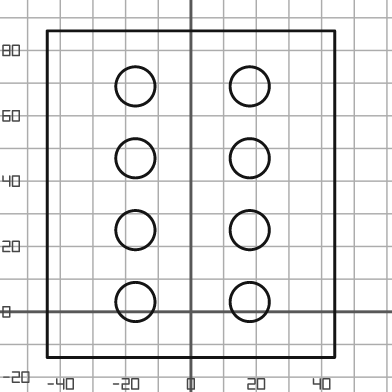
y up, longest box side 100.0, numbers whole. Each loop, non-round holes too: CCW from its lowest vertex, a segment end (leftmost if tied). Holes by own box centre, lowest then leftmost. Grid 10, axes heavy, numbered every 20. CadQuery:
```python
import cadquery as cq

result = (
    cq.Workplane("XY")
    .moveTo(-44.0, -14.0)
    .lineTo(44.0, -14.0)
    .lineTo(44.0, 86.0)
    .lineTo(-44.0, 86.0)
    .close()
    .moveTo(-17.0, 3.0)
    .circle(6.0)
    .moveTo(18.0, 3.0)
    .circle(6.0)
    .moveTo(-17.0, 25.0)
    .circle(6.0)
    .moveTo(18.0, 25.0)
    .circle(6.0)
    .moveTo(-17.0, 47.0)
    .circle(6.0)
    .moveTo(18.0, 47.0)
    .circle(6.0)
    .moveTo(-17.0, 69.0)
    .circle(6.0)
    .moveTo(18.0, 69.0)
    .circle(6.0)
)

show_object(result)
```